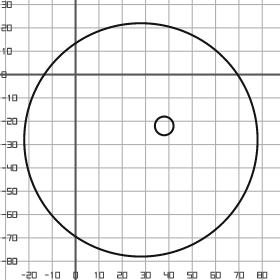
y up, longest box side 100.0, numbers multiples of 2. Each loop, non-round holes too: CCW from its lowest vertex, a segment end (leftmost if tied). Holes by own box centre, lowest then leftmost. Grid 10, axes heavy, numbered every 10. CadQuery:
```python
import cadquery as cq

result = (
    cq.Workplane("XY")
    .moveTo(28.0, -28.0)
    .circle(50.0)
    .moveTo(38.0, -22.0)
    .circle(4.0)
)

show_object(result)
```